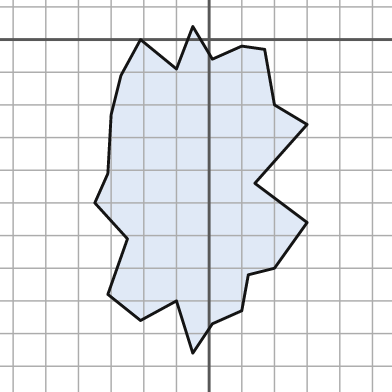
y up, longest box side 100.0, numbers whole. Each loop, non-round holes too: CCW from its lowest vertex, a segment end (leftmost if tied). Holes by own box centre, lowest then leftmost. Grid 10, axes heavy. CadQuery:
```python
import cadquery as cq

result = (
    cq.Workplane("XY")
    .moveTo(-5.0, -96.0)
    .lineTo(1.0, -87.0)
    .lineTo(10.0, -83.0)
    .lineTo(12.0, -72.0)
    .lineTo(20.0, -70.0)
    .lineTo(30.0, -56.0)
    .lineTo(14.0, -44.0)
    .lineTo(30.0, -26.0)
    .lineTo(20.0, -20.0)
    .lineTo(17.0, -3.0)
    .lineTo(10.0, -2.0)
    .lineTo(1.0, -6.0)
    .lineTo(-5.0, 4.0)
    .lineTo(-10.0, -9.0)
    .lineTo(-21.0, 0.0)
    .lineTo(-27.0, -11.0)
    .lineTo(-30.0, -23.0)
    .lineTo(-31.0, -41.0)
    .lineTo(-35.0, -50.0)
    .lineTo(-25.0, -61.0)
    .lineTo(-31.0, -78.0)
    .lineTo(-21.0, -86.0)
    .lineTo(-10.0, -80.0)
    .close()
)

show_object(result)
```